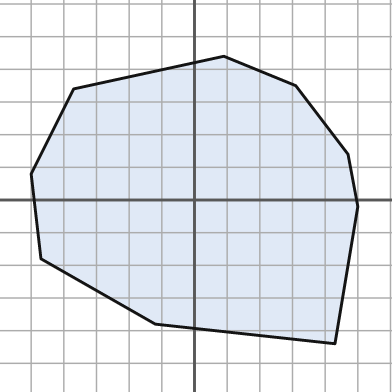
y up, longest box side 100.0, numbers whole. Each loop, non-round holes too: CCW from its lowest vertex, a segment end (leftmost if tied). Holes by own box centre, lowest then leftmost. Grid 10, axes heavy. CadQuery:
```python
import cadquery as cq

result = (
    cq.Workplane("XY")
    .moveTo(43.0, -44.0)
    .lineTo(50.0, -2.0)
    .lineTo(47.0, 14.0)
    .lineTo(31.0, 35.0)
    .lineTo(9.0, 44.0)
    .lineTo(-37.0, 34.0)
    .lineTo(-50.0, 8.0)
    .lineTo(-47.0, -18.0)
    .lineTo(-12.0, -38.0)
    .close()
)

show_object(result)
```